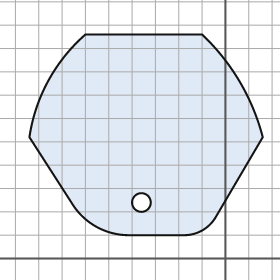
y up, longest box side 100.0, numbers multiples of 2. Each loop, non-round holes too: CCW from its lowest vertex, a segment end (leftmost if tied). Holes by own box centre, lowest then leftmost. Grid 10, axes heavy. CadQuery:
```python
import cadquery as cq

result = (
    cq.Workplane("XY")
    .moveTo(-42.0, 10.0)
    .lineTo(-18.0, 10.0)
    .threePointArc((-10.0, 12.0), (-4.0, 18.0))
    .lineTo(16.0, 52.0)
    .threePointArc((6.0, 76.0), (-10.0, 96.0))
    .lineTo(-60.0, 96.0)
    .threePointArc((-76.0, 76.0), (-84.0, 52.0))
    .lineTo(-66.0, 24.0)
    .threePointArc((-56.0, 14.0), (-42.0, 10.0))
    .close()
    .moveTo(-36.0, 24.0)
    .circle(4.0)
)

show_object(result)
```